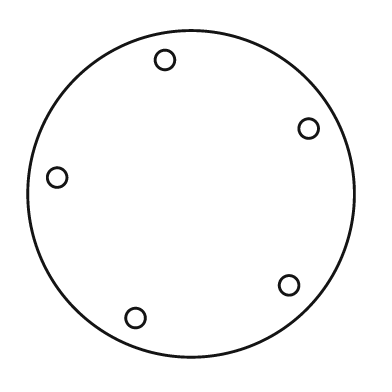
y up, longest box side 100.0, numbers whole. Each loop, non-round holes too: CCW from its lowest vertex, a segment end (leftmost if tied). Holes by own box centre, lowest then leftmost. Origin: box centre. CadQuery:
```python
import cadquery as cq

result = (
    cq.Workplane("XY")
    .moveTo(0.0, 0.0)
    .circle(50.0)
    .moveTo(-17.0, -38.0)
    .circle(3.0)
    .moveTo(30.0, -28.0)
    .circle(3.0)
    .moveTo(-41.0, 5.0)
    .circle(3.0)
    .moveTo(36.0, 20.0)
    .circle(3.0)
    .moveTo(-8.0, 41.0)
    .circle(3.0)
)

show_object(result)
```